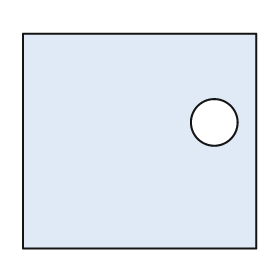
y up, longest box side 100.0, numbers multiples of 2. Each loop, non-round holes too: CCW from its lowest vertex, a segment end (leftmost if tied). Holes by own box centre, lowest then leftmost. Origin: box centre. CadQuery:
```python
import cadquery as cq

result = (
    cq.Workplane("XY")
    .moveTo(-50.0, -46.0)
    .lineTo(50.0, -46.0)
    .lineTo(50.0, 46.0)
    .lineTo(-50.0, 46.0)
    .close()
    .moveTo(32.0, 8.0)
    .circle(10.0)
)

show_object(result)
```